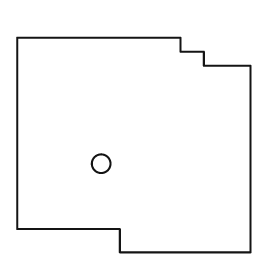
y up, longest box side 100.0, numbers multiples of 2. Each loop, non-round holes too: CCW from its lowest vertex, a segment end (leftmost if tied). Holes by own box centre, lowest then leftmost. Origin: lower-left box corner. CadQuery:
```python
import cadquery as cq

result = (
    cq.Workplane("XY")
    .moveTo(44.0, 0.0)
    .lineTo(100.0, 0.0)
    .lineTo(100.0, 80.0)
    .lineTo(80.0, 80.0)
    .lineTo(80.0, 86.0)
    .lineTo(70.0, 86.0)
    .lineTo(70.0, 92.0)
    .lineTo(0.0, 92.0)
    .lineTo(0.0, 10.0)
    .lineTo(44.0, 10.0)
    .close()
    .moveTo(36.0, 38.0)
    .circle(4.0)
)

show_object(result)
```